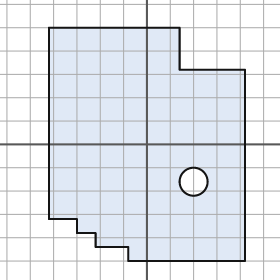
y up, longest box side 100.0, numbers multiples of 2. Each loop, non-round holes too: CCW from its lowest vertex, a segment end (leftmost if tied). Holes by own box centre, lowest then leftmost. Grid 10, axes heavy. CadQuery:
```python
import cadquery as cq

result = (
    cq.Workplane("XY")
    .moveTo(-8.0, -50.0)
    .lineTo(42.0, -50.0)
    .lineTo(42.0, 32.0)
    .lineTo(14.0, 32.0)
    .lineTo(14.0, 50.0)
    .lineTo(-42.0, 50.0)
    .lineTo(-42.0, -32.0)
    .lineTo(-30.0, -32.0)
    .lineTo(-30.0, -38.0)
    .lineTo(-22.0, -38.0)
    .lineTo(-22.0, -44.0)
    .lineTo(-8.0, -44.0)
    .close()
    .moveTo(20.0, -16.0)
    .circle(6.0)
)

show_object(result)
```